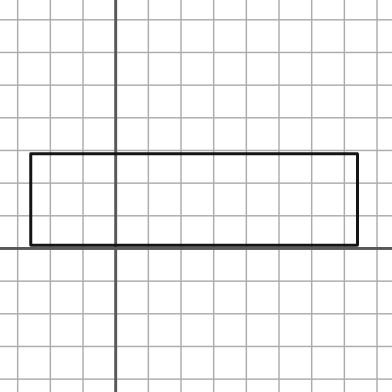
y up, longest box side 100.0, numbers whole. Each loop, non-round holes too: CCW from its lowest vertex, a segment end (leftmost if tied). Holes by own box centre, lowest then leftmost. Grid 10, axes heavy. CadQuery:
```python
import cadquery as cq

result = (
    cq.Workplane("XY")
    .moveTo(-26.0, 1.0)
    .lineTo(74.0, 1.0)
    .lineTo(74.0, 29.0)
    .lineTo(-26.0, 29.0)
    .close()
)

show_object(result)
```